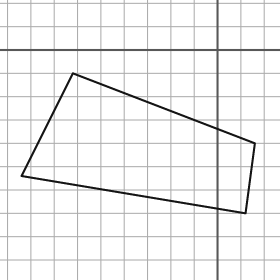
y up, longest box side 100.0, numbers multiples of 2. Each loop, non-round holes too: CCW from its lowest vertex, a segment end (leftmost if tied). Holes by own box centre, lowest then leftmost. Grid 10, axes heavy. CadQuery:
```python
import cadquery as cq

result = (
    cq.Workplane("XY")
    .moveTo(12.0, -70.0)
    .lineTo(16.0, -40.0)
    .lineTo(-62.0, -10.0)
    .lineTo(-84.0, -54.0)
    .close()
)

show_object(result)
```